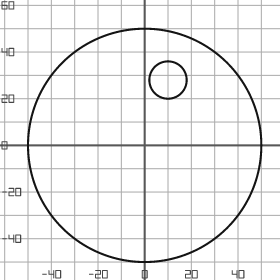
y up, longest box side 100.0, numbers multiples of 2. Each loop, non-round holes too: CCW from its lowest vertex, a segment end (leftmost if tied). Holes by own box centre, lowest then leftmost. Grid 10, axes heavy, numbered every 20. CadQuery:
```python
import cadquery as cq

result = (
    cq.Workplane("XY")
    .moveTo(0.0, 0.0)
    .circle(50.0)
    .moveTo(10.0, 28.0)
    .circle(8.0)
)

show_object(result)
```